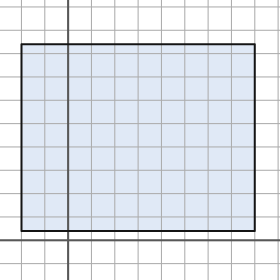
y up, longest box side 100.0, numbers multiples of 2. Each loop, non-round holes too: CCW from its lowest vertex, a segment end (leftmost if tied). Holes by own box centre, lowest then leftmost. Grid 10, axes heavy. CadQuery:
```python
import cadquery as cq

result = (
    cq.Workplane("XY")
    .moveTo(-20.0, 4.0)
    .lineTo(80.0, 4.0)
    .lineTo(80.0, 84.0)
    .lineTo(-20.0, 84.0)
    .close()
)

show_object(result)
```